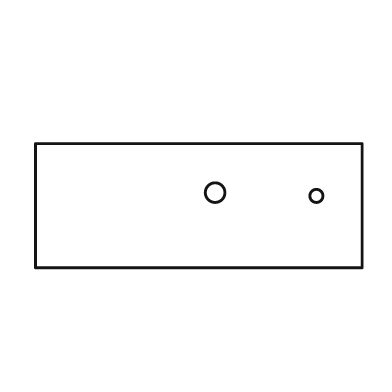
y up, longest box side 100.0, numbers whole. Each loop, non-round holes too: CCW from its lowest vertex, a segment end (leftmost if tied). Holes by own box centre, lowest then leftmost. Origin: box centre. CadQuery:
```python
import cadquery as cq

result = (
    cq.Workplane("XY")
    .moveTo(-50.0, -19.0)
    .lineTo(50.0, -19.0)
    .lineTo(50.0, 19.0)
    .lineTo(-50.0, 19.0)
    .close()
    .moveTo(36.0, 3.0)
    .circle(2.0)
    .moveTo(5.0, 4.0)
    .circle(3.0)
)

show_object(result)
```